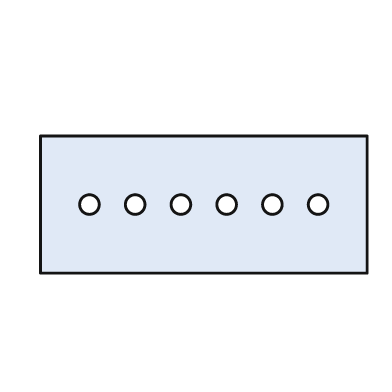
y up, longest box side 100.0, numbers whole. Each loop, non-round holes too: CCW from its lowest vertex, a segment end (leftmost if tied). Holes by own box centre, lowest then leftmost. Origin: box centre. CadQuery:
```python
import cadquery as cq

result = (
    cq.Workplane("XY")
    .moveTo(-50.0, -21.0)
    .lineTo(50.0, -21.0)
    .lineTo(50.0, 21.0)
    .lineTo(-50.0, 21.0)
    .close()
    .moveTo(-35.0, 0.0)
    .circle(3.0)
    .moveTo(-21.0, 0.0)
    .circle(3.0)
    .moveTo(-7.0, 0.0)
    .circle(3.0)
    .moveTo(7.0, 0.0)
    .circle(3.0)
    .moveTo(21.0, 0.0)
    .circle(3.0)
    .moveTo(35.0, 0.0)
    .circle(3.0)
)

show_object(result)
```